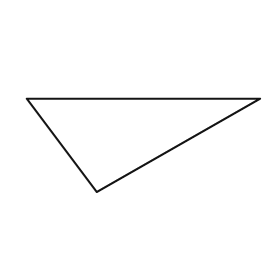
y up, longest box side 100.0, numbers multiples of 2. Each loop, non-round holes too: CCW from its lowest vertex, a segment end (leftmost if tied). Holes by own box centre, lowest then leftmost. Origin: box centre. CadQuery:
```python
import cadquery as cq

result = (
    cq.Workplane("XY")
    .moveTo(-20.0, -20.0)
    .lineTo(50.0, 20.0)
    .lineTo(-50.0, 20.0)
    .close()
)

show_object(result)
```